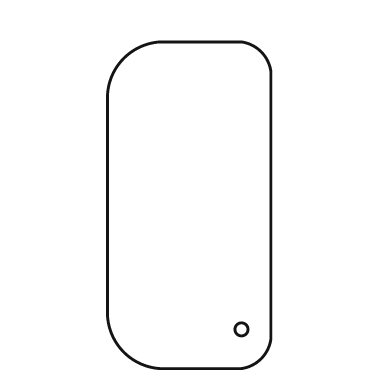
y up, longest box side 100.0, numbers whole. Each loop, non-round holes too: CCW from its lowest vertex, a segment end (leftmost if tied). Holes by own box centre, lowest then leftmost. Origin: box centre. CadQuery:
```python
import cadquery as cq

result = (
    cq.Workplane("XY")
    .moveTo(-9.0, -50.0)
    .lineTo(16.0, -50.0)
    .threePointArc((22.0, -47.0), (25.0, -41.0))
    .lineTo(25.0, 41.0)
    .threePointArc((22.0, 47.0), (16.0, 50.0))
    .lineTo(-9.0, 50.0)
    .threePointArc((-20.0, 45.0), (-25.0, 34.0))
    .lineTo(-25.0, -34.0)
    .threePointArc((-20.0, -45.0), (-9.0, -50.0))
    .close()
    .moveTo(16.0, -38.0)
    .circle(2.0)
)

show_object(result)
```